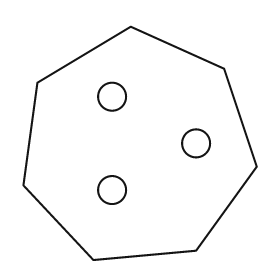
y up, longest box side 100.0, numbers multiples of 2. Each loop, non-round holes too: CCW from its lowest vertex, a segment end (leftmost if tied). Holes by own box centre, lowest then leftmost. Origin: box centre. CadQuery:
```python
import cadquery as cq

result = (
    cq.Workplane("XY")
    .moveTo(-20.0, -50.0)
    .lineTo(24.0, -46.0)
    .lineTo(50.0, -10.0)
    .lineTo(36.0, 32.0)
    .lineTo(-4.0, 50.0)
    .lineTo(-44.0, 26.0)
    .lineTo(-50.0, -18.0)
    .close()
    .moveTo(-12.0, -20.0)
    .circle(6.0)
    .moveTo(24.0, 0.0)
    .circle(6.0)
    .moveTo(-12.0, 20.0)
    .circle(6.0)
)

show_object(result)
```